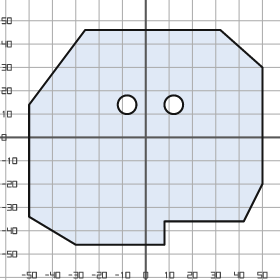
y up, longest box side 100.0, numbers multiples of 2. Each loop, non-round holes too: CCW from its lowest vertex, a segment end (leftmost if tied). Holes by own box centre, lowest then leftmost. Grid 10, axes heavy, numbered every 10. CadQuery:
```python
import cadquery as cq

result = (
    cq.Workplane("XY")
    .moveTo(-30.0, -46.0)
    .lineTo(8.0, -46.0)
    .lineTo(8.0, -36.0)
    .lineTo(42.0, -36.0)
    .lineTo(50.0, -20.0)
    .lineTo(50.0, 30.0)
    .lineTo(32.0, 46.0)
    .lineTo(-26.0, 46.0)
    .lineTo(-50.0, 14.0)
    .lineTo(-50.0, -34.0)
    .close()
    .moveTo(-8.0, 14.0)
    .circle(4.0)
    .moveTo(12.0, 14.0)
    .circle(4.0)
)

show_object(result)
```